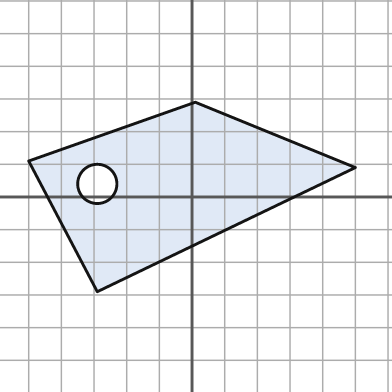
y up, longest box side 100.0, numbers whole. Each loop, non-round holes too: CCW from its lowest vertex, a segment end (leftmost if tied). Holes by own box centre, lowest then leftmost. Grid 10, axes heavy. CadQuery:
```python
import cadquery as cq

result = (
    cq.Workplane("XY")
    .moveTo(-29.0, -29.0)
    .lineTo(50.0, 9.0)
    .lineTo(1.0, 29.0)
    .lineTo(-50.0, 11.0)
    .close()
    .moveTo(-29.0, 4.0)
    .circle(6.0)
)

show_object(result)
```